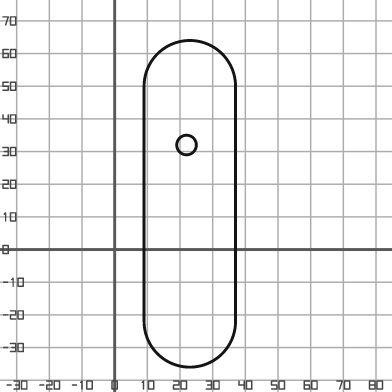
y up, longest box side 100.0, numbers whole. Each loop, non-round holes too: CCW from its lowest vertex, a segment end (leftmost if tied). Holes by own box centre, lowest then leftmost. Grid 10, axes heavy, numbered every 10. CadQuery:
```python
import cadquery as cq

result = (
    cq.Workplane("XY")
    .moveTo(9.0, -22.0)
    .threePointArc((23.0, -36.0), (37.0, -22.0))
    .lineTo(37.0, 50.0)
    .threePointArc((23.0, 64.0), (9.0, 50.0))
    .close()
    .moveTo(22.0, 32.0)
    .circle(3.0)
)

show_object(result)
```